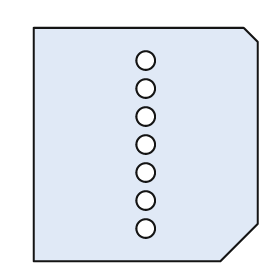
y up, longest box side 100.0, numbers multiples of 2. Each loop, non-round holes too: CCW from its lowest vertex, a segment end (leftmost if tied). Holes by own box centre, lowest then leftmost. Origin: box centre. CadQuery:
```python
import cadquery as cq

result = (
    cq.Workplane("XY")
    .moveTo(-48.0, -50.0)
    .lineTo(32.0, -50.0)
    .lineTo(48.0, -34.0)
    .lineTo(48.0, 44.0)
    .lineTo(42.0, 50.0)
    .lineTo(-48.0, 50.0)
    .close()
    .moveTo(0.0, -36.0)
    .circle(4.0)
    .moveTo(0.0, -24.0)
    .circle(4.0)
    .moveTo(0.0, -12.0)
    .circle(4.0)
    .moveTo(0.0, 0.0)
    .circle(4.0)
    .moveTo(0.0, 12.0)
    .circle(4.0)
    .moveTo(0.0, 24.0)
    .circle(4.0)
    .moveTo(0.0, 36.0)
    .circle(4.0)
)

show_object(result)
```